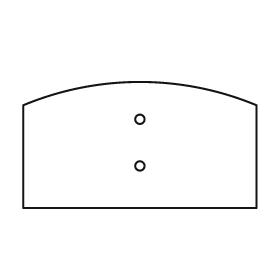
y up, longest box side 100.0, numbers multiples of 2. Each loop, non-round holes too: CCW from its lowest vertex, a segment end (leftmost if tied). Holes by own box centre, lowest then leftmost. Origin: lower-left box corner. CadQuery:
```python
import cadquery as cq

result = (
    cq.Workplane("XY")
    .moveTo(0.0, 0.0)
    .lineTo(100.0, 0.0)
    .lineTo(100.0, 44.0)
    .threePointArc((50.0, 54.0), (0.0, 44.0))
    .close()
    .moveTo(50.0, 18.0)
    .circle(2.0)
    .moveTo(50.0, 38.0)
    .circle(2.0)
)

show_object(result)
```